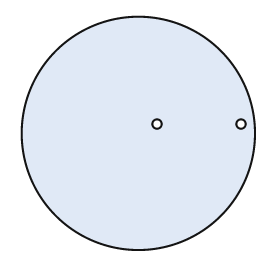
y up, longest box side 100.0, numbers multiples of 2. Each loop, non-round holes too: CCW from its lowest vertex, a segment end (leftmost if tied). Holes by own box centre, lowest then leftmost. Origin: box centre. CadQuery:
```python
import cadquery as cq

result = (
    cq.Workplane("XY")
    .moveTo(0.0, 0.0)
    .circle(50.0)
    .moveTo(8.0, 4.0)
    .circle(2.0)
    .moveTo(44.0, 4.0)
    .circle(2.0)
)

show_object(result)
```